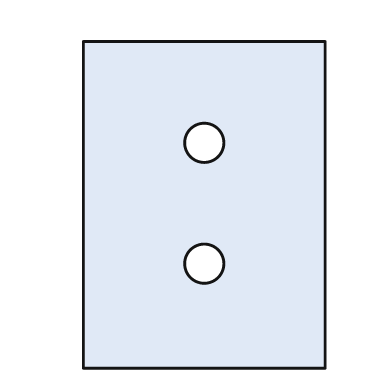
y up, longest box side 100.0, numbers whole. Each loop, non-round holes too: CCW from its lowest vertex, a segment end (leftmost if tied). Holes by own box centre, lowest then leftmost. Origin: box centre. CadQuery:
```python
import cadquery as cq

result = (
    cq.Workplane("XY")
    .moveTo(-37.0, -50.0)
    .lineTo(37.0, -50.0)
    .lineTo(37.0, 50.0)
    .lineTo(-37.0, 50.0)
    .close()
    .moveTo(0.0, -18.0)
    .circle(6.0)
    .moveTo(0.0, 19.0)
    .circle(6.0)
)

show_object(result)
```